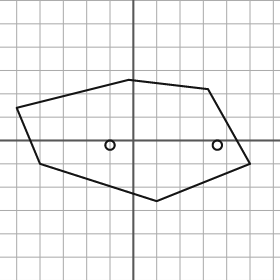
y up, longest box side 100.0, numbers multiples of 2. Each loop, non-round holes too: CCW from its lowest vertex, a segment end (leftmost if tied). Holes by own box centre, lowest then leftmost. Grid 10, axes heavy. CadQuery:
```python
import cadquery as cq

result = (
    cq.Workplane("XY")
    .moveTo(10.0, -26.0)
    .lineTo(50.0, -10.0)
    .lineTo(32.0, 22.0)
    .lineTo(-2.0, 26.0)
    .lineTo(-50.0, 14.0)
    .lineTo(-40.0, -10.0)
    .close()
    .moveTo(-10.0, -2.0)
    .circle(2.0)
    .moveTo(36.0, -2.0)
    .circle(2.0)
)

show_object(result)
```